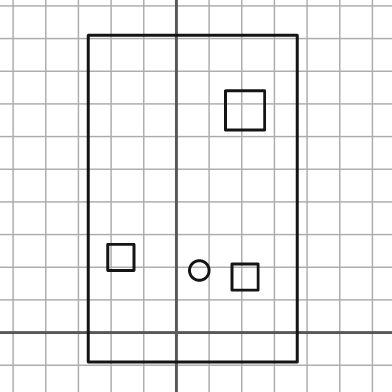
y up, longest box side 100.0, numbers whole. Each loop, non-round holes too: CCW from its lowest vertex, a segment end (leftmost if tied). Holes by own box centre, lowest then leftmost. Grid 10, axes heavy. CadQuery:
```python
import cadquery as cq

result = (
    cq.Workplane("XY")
    .moveTo(-27.0, -9.0)
    .lineTo(37.0, -9.0)
    .lineTo(37.0, 91.0)
    .lineTo(-27.0, 91.0)
    .close()
    .moveTo(17.0, 13.0)
    .lineTo(25.0, 13.0)
    .lineTo(25.0, 21.0)
    .lineTo(17.0, 21.0)
    .close()
    .moveTo(7.0, 19.0)
    .circle(3.0)
    .moveTo(-21.0, 19.0)
    .lineTo(-13.0, 19.0)
    .lineTo(-13.0, 27.0)
    .lineTo(-21.0, 27.0)
    .close()
    .moveTo(15.0, 62.0)
    .lineTo(27.0, 62.0)
    .lineTo(27.0, 74.0)
    .lineTo(15.0, 74.0)
    .close()
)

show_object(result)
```